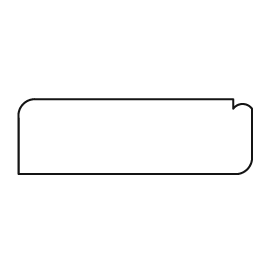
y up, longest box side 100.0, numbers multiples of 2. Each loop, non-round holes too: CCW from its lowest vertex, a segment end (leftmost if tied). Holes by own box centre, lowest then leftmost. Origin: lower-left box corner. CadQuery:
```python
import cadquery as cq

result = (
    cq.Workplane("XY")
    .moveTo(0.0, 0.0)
    .lineTo(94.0, 0.0)
    .threePointArc((98.0, 2.0), (100.0, 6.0))
    .lineTo(100.0, 28.0)
    .threePointArc((96.0, 30.0), (92.0, 28.0))
    .lineTo(92.0, 32.0)
    .lineTo(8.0, 32.0)
    .threePointArc((2.0, 30.0), (0.0, 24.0))
    .close()
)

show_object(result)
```